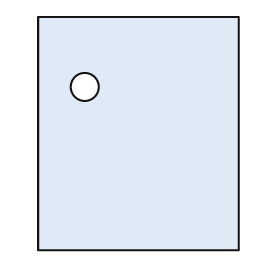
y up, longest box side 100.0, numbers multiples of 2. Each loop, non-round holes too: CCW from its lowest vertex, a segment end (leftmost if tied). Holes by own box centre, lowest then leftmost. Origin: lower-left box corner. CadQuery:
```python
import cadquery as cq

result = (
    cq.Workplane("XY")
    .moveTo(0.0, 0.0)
    .lineTo(86.0, 0.0)
    .lineTo(86.0, 100.0)
    .lineTo(0.0, 100.0)
    .close()
    .moveTo(20.0, 70.0)
    .circle(6.0)
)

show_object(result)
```